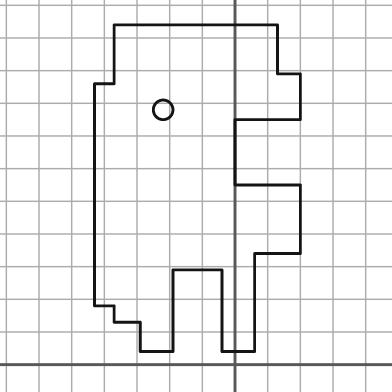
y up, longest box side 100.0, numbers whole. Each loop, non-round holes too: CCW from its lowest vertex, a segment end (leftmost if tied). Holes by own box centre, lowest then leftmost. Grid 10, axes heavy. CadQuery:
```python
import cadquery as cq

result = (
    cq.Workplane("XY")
    .moveTo(-29.0, 4.0)
    .lineTo(-19.0, 4.0)
    .lineTo(-19.0, 29.0)
    .lineTo(-4.0, 29.0)
    .lineTo(-4.0, 4.0)
    .lineTo(6.0, 4.0)
    .lineTo(6.0, 34.0)
    .lineTo(20.0, 34.0)
    .lineTo(20.0, 55.0)
    .lineTo(0.0, 55.0)
    .lineTo(0.0, 75.0)
    .lineTo(20.0, 75.0)
    .lineTo(20.0, 89.0)
    .lineTo(13.0, 89.0)
    .lineTo(13.0, 104.0)
    .lineTo(-37.0, 104.0)
    .lineTo(-37.0, 86.0)
    .lineTo(-43.0, 86.0)
    .lineTo(-43.0, 18.0)
    .lineTo(-37.0, 18.0)
    .lineTo(-37.0, 13.0)
    .lineTo(-29.0, 13.0)
    .close()
    .moveTo(-22.0, 78.0)
    .circle(3.0)
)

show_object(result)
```